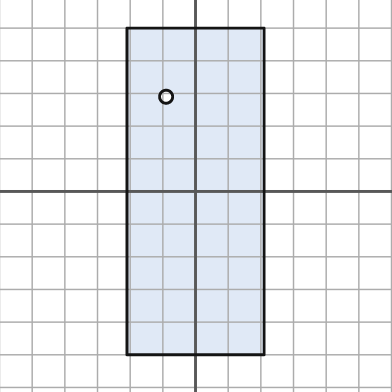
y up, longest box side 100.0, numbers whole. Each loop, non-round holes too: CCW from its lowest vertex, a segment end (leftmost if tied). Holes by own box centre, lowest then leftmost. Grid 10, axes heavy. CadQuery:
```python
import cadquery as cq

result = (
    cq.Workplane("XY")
    .moveTo(-21.0, -50.0)
    .lineTo(21.0, -50.0)
    .lineTo(21.0, 50.0)
    .lineTo(-21.0, 50.0)
    .close()
    .moveTo(-9.0, 29.0)
    .circle(2.0)
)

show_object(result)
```